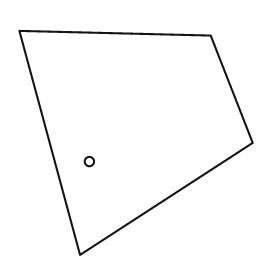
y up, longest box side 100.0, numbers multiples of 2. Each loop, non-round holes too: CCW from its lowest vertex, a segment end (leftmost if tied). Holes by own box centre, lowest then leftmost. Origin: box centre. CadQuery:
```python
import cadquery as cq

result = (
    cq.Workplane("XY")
    .moveTo(-24.0, -48.0)
    .lineTo(50.0, 0.0)
    .lineTo(32.0, 46.0)
    .lineTo(-50.0, 48.0)
    .close()
    .moveTo(-20.0, -8.0)
    .circle(2.0)
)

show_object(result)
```